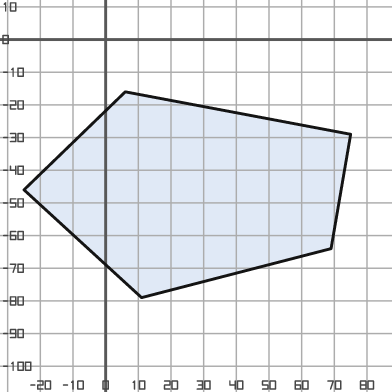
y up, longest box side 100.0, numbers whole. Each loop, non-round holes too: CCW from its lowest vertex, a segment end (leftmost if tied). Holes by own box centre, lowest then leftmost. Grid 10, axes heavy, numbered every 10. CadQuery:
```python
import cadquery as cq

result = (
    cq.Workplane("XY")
    .moveTo(11.0, -79.0)
    .lineTo(69.0, -64.0)
    .lineTo(75.0, -29.0)
    .lineTo(6.0, -16.0)
    .lineTo(-25.0, -46.0)
    .close()
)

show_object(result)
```